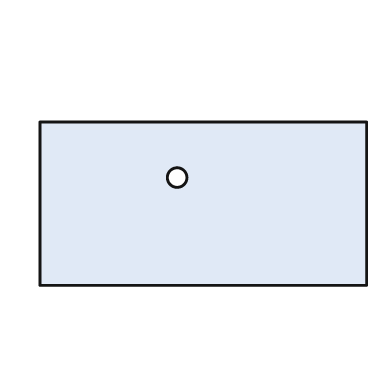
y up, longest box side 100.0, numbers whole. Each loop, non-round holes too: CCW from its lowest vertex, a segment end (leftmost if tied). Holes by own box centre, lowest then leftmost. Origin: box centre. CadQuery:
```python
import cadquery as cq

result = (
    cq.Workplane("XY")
    .moveTo(-50.0, -25.0)
    .lineTo(50.0, -25.0)
    .lineTo(50.0, 25.0)
    .lineTo(-50.0, 25.0)
    .close()
    .moveTo(-8.0, 8.0)
    .circle(3.0)
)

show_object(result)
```